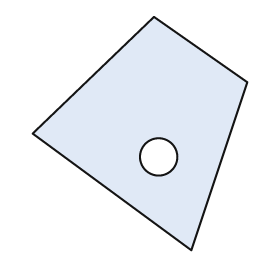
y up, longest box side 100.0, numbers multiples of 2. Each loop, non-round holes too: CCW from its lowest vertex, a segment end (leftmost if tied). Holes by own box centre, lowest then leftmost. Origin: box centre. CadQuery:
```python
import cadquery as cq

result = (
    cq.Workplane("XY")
    .moveTo(22.0, -50.0)
    .lineTo(46.0, 22.0)
    .lineTo(6.0, 50.0)
    .lineTo(-46.0, 0.0)
    .close()
    .moveTo(8.0, -10.0)
    .circle(8.0)
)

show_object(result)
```